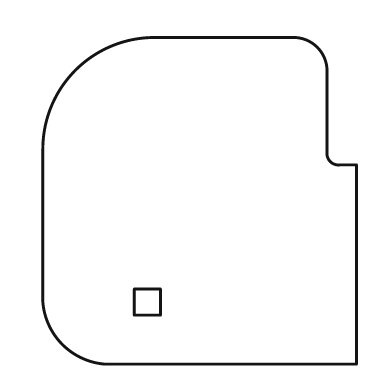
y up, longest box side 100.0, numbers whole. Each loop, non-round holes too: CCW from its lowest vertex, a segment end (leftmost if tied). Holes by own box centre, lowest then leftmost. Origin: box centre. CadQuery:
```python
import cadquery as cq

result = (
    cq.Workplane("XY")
    .moveTo(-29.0, -50.0)
    .lineTo(48.0, -50.0)
    .lineTo(48.0, 11.0)
    .lineTo(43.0, 11.0)
    .threePointArc((40.0, 12.0), (39.0, 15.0))
    .lineTo(39.0, 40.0)
    .threePointArc((36.0, 47.0), (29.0, 50.0))
    .lineTo(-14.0, 50.0)
    .threePointArc((-38.0, 40.0), (-48.0, 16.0))
    .lineTo(-48.0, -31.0)
    .threePointArc((-42.0, -44.0), (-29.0, -50.0))
    .close()
    .moveTo(-20.0, -35.0)
    .lineTo(-12.0, -35.0)
    .lineTo(-12.0, -27.0)
    .lineTo(-20.0, -27.0)
    .close()
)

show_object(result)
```